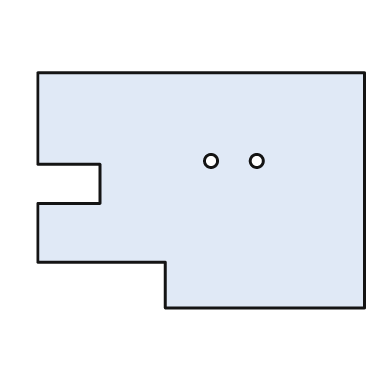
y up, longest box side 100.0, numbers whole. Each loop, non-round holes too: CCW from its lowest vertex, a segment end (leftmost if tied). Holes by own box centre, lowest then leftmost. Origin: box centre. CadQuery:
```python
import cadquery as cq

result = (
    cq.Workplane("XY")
    .moveTo(-11.0, -36.0)
    .lineTo(50.0, -36.0)
    .lineTo(50.0, 36.0)
    .lineTo(-50.0, 36.0)
    .lineTo(-50.0, 8.0)
    .lineTo(-31.0, 8.0)
    .lineTo(-31.0, -4.0)
    .lineTo(-50.0, -4.0)
    .lineTo(-50.0, -22.0)
    .lineTo(-11.0, -22.0)
    .close()
    .moveTo(3.0, 9.0)
    .circle(2.0)
    .moveTo(17.0, 9.0)
    .circle(2.0)
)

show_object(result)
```